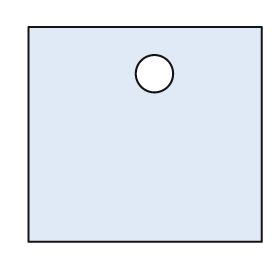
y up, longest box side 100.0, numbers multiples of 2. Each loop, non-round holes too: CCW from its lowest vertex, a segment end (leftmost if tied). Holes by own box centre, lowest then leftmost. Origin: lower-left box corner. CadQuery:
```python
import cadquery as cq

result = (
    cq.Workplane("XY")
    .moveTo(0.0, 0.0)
    .lineTo(100.0, 0.0)
    .lineTo(100.0, 92.0)
    .lineTo(0.0, 92.0)
    .close()
    .moveTo(54.0, 72.0)
    .circle(8.0)
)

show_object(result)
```